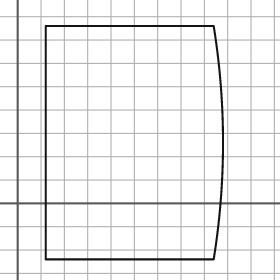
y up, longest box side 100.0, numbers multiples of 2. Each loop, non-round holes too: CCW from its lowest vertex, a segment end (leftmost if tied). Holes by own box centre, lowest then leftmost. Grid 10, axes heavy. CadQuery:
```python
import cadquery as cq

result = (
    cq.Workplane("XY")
    .moveTo(12.0, -24.0)
    .lineTo(84.0, -24.0)
    .threePointArc((88.0, 26.0), (84.0, 76.0))
    .lineTo(12.0, 76.0)
    .close()
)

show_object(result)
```